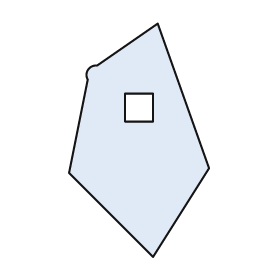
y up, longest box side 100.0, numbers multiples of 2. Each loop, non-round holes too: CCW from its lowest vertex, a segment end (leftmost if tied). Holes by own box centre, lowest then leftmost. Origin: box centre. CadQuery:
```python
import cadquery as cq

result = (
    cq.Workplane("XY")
    .moveTo(6.0, -50.0)
    .lineTo(30.0, -12.0)
    .lineTo(8.0, 50.0)
    .lineTo(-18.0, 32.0)
    .threePointArc((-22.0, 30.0), (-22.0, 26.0))
    .lineTo(-30.0, -14.0)
    .close()
    .moveTo(-6.0, 8.0)
    .lineTo(6.0, 8.0)
    .lineTo(6.0, 20.0)
    .lineTo(-6.0, 20.0)
    .close()
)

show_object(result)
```